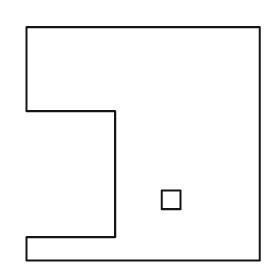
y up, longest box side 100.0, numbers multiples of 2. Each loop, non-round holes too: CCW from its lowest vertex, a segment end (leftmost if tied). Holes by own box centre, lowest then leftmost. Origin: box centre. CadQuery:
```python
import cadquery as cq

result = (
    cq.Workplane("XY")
    .moveTo(-50.0, -50.0)
    .lineTo(50.0, -50.0)
    .lineTo(50.0, 50.0)
    .lineTo(-50.0, 50.0)
    .lineTo(-50.0, 14.0)
    .lineTo(-12.0, 14.0)
    .lineTo(-12.0, -40.0)
    .lineTo(-50.0, -40.0)
    .close()
    .moveTo(8.0, -28.0)
    .lineTo(16.0, -28.0)
    .lineTo(16.0, -20.0)
    .lineTo(8.0, -20.0)
    .close()
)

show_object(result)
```